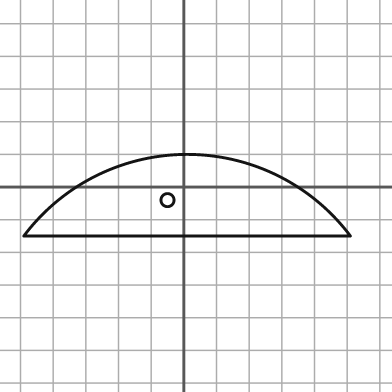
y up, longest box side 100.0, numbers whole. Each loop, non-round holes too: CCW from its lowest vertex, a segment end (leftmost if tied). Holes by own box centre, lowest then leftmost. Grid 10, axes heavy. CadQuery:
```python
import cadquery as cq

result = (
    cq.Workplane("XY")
    .moveTo(-49.0, -15.0)
    .lineTo(51.0, -15.0)
    .threePointArc((1.0, 10.0), (-49.0, -15.0))
    .close()
    .moveTo(-5.0, -4.0)
    .circle(2.0)
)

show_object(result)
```